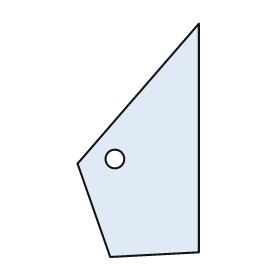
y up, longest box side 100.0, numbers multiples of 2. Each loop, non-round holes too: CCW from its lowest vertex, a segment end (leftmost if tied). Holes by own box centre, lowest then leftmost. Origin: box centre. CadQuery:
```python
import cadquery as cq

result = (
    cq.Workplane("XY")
    .moveTo(-12.0, -50.0)
    .lineTo(26.0, -48.0)
    .lineTo(26.0, 50.0)
    .lineTo(-26.0, -10.0)
    .close()
    .moveTo(-10.0, -8.0)
    .circle(4.0)
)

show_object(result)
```